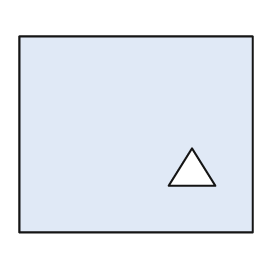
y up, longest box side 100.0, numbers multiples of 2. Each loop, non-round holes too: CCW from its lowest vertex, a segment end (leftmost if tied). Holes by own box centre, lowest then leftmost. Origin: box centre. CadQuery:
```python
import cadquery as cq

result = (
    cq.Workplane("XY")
    .moveTo(-50.0, -42.0)
    .lineTo(50.0, -42.0)
    .lineTo(50.0, 42.0)
    .lineTo(-50.0, 42.0)
    .close()
    .moveTo(14.0, -22.0)
    .lineTo(34.0, -22.0)
    .lineTo(24.0, -6.0)
    .close()
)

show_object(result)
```